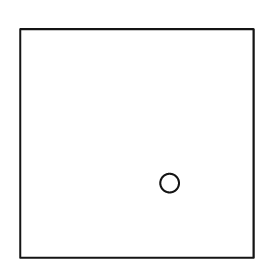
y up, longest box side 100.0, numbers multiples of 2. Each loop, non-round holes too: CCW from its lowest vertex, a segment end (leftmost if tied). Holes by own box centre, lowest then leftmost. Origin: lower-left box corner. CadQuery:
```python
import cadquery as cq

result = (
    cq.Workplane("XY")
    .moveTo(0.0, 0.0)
    .lineTo(100.0, 0.0)
    .lineTo(100.0, 98.0)
    .lineTo(0.0, 98.0)
    .close()
    .moveTo(64.0, 32.0)
    .circle(4.0)
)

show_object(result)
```